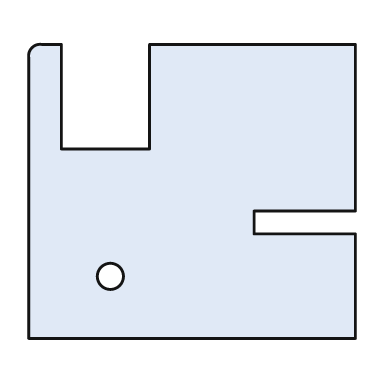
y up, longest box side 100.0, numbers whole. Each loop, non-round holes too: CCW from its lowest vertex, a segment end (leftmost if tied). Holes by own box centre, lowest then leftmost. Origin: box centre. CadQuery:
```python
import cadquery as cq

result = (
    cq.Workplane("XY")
    .moveTo(-50.0, -45.0)
    .lineTo(50.0, -45.0)
    .lineTo(50.0, -13.0)
    .lineTo(19.0, -13.0)
    .lineTo(19.0, -6.0)
    .lineTo(50.0, -6.0)
    .lineTo(50.0, 45.0)
    .lineTo(-13.0, 45.0)
    .lineTo(-13.0, 13.0)
    .lineTo(-40.0, 13.0)
    .lineTo(-40.0, 45.0)
    .lineTo(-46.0, 45.0)
    .threePointArc((-49.0, 44.0), (-50.0, 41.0))
    .close()
    .moveTo(-25.0, -26.0)
    .circle(4.0)
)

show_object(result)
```